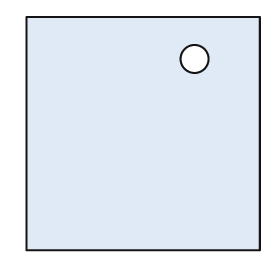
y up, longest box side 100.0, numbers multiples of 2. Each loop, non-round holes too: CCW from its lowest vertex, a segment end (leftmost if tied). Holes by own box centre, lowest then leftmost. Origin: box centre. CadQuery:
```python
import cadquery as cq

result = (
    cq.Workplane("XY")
    .moveTo(-50.0, -50.0)
    .lineTo(50.0, -50.0)
    .lineTo(50.0, 50.0)
    .lineTo(-50.0, 50.0)
    .close()
    .moveTo(22.0, 32.0)
    .circle(6.0)
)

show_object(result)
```